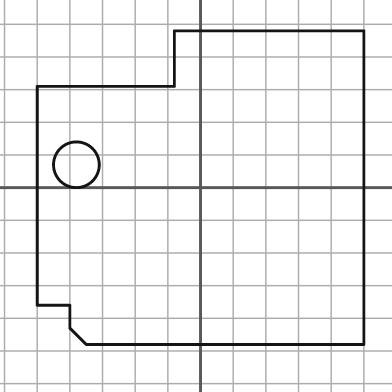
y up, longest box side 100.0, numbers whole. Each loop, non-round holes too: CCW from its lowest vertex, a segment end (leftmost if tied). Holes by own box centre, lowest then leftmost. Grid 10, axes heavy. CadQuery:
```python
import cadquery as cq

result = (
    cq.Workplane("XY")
    .moveTo(-35.0, -48.0)
    .lineTo(50.0, -48.0)
    .lineTo(50.0, 48.0)
    .lineTo(-8.0, 48.0)
    .lineTo(-8.0, 31.0)
    .lineTo(-50.0, 31.0)
    .lineTo(-50.0, -36.0)
    .lineTo(-40.0, -36.0)
    .lineTo(-40.0, -43.0)
    .close()
    .moveTo(-38.0, 7.0)
    .circle(7.0)
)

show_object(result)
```